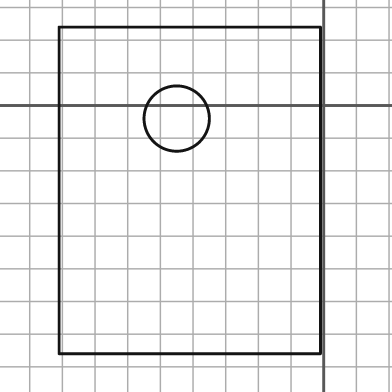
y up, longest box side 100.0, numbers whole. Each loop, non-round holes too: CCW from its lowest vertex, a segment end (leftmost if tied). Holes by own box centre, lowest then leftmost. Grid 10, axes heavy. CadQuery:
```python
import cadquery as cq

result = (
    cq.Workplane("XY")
    .moveTo(-81.0, -76.0)
    .lineTo(-1.0, -76.0)
    .lineTo(-1.0, 24.0)
    .lineTo(-81.0, 24.0)
    .close()
    .moveTo(-45.0, -4.0)
    .circle(10.0)
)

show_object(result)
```